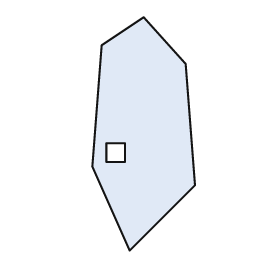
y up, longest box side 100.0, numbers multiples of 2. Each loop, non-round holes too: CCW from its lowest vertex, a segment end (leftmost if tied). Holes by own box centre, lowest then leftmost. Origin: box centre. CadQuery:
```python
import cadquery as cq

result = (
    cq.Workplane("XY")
    .moveTo(-6.0, -50.0)
    .lineTo(22.0, -22.0)
    .lineTo(18.0, 30.0)
    .lineTo(0.0, 50.0)
    .lineTo(-18.0, 38.0)
    .lineTo(-22.0, -14.0)
    .close()
    .moveTo(-16.0, -12.0)
    .lineTo(-8.0, -12.0)
    .lineTo(-8.0, -4.0)
    .lineTo(-16.0, -4.0)
    .close()
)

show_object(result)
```